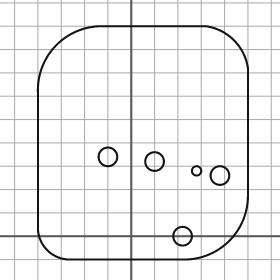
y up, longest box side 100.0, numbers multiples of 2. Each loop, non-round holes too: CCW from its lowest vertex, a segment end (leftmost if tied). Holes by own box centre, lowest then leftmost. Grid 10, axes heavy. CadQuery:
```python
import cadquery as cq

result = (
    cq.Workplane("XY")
    .moveTo(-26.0, -10.0)
    .lineTo(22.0, -10.0)
    .threePointArc((42.0, -2.0), (50.0, 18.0))
    .lineTo(50.0, 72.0)
    .threePointArc((44.0, 84.0), (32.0, 90.0))
    .lineTo(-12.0, 90.0)
    .threePointArc((-32.0, 82.0), (-40.0, 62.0))
    .lineTo(-40.0, 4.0)
    .threePointArc((-36.0, -6.0), (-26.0, -10.0))
    .close()
    .moveTo(22.0, 0.0)
    .circle(4.0)
    .moveTo(38.0, 26.0)
    .circle(4.0)
    .moveTo(28.0, 28.0)
    .circle(2.0)
    .moveTo(10.0, 32.0)
    .circle(4.0)
    .moveTo(-10.0, 34.0)
    .circle(4.0)
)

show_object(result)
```